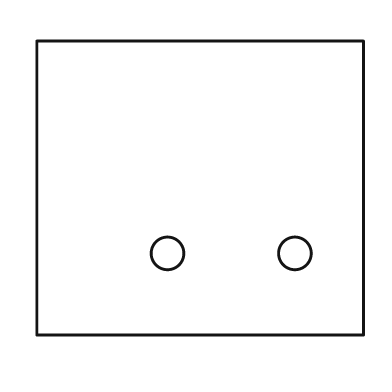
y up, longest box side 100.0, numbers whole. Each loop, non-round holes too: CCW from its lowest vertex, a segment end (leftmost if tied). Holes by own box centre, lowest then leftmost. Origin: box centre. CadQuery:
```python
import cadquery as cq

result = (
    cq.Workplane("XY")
    .moveTo(-50.0, -45.0)
    .lineTo(50.0, -45.0)
    .lineTo(50.0, 45.0)
    .lineTo(-50.0, 45.0)
    .close()
    .moveTo(-10.0, -20.0)
    .circle(5.0)
    .moveTo(29.0, -20.0)
    .circle(5.0)
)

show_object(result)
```